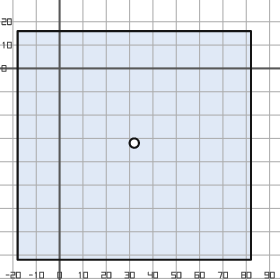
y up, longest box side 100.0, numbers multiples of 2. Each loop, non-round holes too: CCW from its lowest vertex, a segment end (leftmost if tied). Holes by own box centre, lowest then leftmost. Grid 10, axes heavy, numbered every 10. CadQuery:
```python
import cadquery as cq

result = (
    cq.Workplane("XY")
    .moveTo(-18.0, -82.0)
    .lineTo(82.0, -82.0)
    .lineTo(82.0, 16.0)
    .lineTo(-18.0, 16.0)
    .close()
    .moveTo(32.0, -32.0)
    .circle(2.0)
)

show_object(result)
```